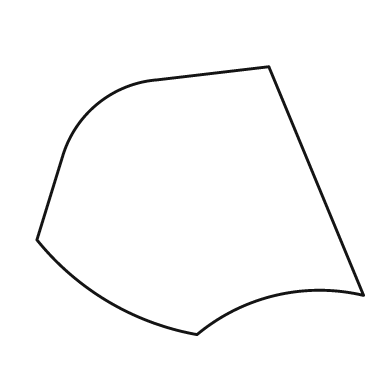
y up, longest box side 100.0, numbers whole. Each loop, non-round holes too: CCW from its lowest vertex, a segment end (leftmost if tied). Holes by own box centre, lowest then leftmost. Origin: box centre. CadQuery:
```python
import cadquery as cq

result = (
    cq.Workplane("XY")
    .moveTo(-1.0, -41.0)
    .threePointArc((23.0, -29.0), (50.0, -29.0))
    .lineTo(21.0, 41.0)
    .lineTo(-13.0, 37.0)
    .threePointArc((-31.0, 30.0), (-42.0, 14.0))
    .lineTo(-50.0, -12.0)
    .threePointArc((-28.0, -31.0), (-1.0, -41.0))
    .close()
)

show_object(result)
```